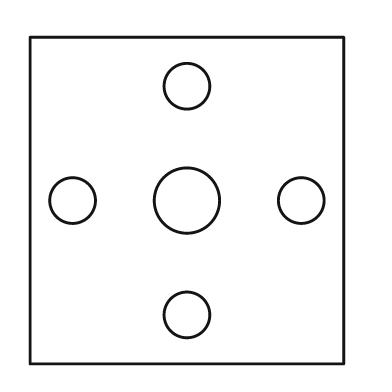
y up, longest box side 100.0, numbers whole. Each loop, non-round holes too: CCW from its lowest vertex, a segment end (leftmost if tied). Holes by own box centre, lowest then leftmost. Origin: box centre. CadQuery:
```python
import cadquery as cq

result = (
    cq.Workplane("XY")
    .moveTo(-48.0, -50.0)
    .lineTo(48.0, -50.0)
    .lineTo(48.0, 50.0)
    .lineTo(-48.0, 50.0)
    .close()
    .moveTo(0.0, -35.0)
    .circle(7.0)
    .moveTo(-35.0, 0.0)
    .circle(7.0)
    .moveTo(0.0, 0.0)
    .circle(10.0)
    .moveTo(35.0, 0.0)
    .circle(7.0)
    .moveTo(0.0, 35.0)
    .circle(7.0)
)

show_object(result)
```